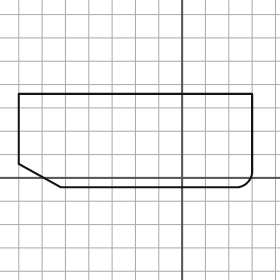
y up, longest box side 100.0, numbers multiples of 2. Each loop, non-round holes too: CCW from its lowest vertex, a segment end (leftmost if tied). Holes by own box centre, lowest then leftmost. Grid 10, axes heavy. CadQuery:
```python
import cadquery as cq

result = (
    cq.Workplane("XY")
    .moveTo(-52.0, -4.0)
    .lineTo(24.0, -4.0)
    .threePointArc((28.0, -2.0), (30.0, 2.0))
    .lineTo(30.0, 36.0)
    .lineTo(-70.0, 36.0)
    .lineTo(-70.0, 6.0)
    .close()
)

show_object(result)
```